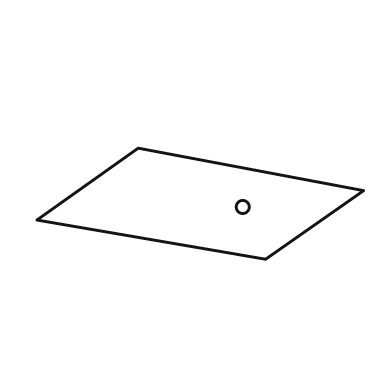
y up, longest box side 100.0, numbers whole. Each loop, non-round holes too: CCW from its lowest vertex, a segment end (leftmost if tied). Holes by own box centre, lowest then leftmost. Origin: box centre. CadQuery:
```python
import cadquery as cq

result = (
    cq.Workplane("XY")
    .moveTo(20.0, -17.0)
    .lineTo(50.0, 4.0)
    .lineTo(-19.0, 17.0)
    .lineTo(-50.0, -5.0)
    .close()
    .moveTo(13.0, -1.0)
    .circle(2.0)
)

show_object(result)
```